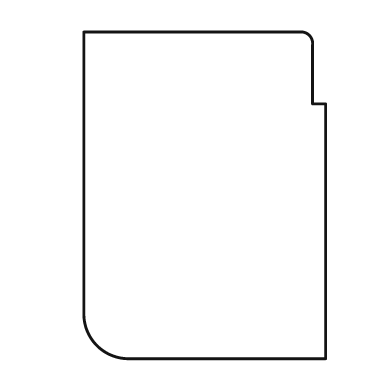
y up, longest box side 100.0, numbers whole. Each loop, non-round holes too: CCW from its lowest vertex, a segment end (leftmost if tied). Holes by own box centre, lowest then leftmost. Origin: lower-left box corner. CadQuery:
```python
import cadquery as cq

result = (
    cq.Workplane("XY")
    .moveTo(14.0, 0.0)
    .lineTo(74.0, 0.0)
    .lineTo(74.0, 78.0)
    .lineTo(70.0, 78.0)
    .lineTo(70.0, 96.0)
    .threePointArc((69.0, 99.0), (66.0, 100.0))
    .lineTo(0.0, 100.0)
    .lineTo(0.0, 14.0)
    .threePointArc((4.0, 4.0), (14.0, 0.0))
    .close()
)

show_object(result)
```